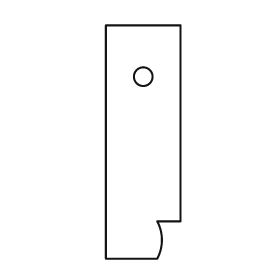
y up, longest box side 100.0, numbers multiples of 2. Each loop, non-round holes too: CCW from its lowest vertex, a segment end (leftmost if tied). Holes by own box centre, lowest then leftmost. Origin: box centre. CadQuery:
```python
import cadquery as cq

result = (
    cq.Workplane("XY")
    .moveTo(-16.0, -50.0)
    .lineTo(6.0, -50.0)
    .threePointArc((8.0, -42.0), (6.0, -34.0))
    .lineTo(16.0, -34.0)
    .lineTo(16.0, 50.0)
    .lineTo(-16.0, 50.0)
    .close()
    .moveTo(0.0, 28.0)
    .circle(4.0)
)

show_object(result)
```